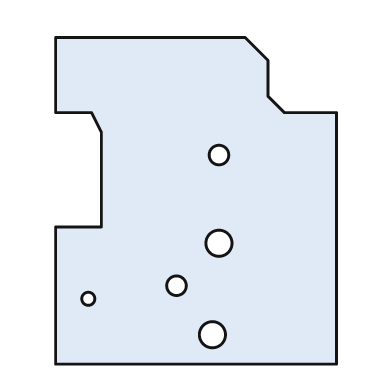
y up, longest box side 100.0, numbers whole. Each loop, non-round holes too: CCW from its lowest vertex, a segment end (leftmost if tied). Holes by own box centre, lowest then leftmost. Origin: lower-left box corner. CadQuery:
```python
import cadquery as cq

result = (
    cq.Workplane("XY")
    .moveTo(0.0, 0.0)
    .lineTo(86.0, 0.0)
    .lineTo(86.0, 77.0)
    .lineTo(70.0, 77.0)
    .lineTo(65.0, 82.0)
    .lineTo(65.0, 93.0)
    .lineTo(58.0, 100.0)
    .lineTo(0.0, 100.0)
    .lineTo(0.0, 77.0)
    .lineTo(11.0, 77.0)
    .lineTo(14.0, 71.0)
    .lineTo(14.0, 42.0)
    .lineTo(0.0, 42.0)
    .close()
    .moveTo(48.0, 9.0)
    .circle(4.0)
    .moveTo(10.0, 20.0)
    .circle(2.0)
    .moveTo(37.0, 24.0)
    .circle(3.0)
    .moveTo(50.0, 37.0)
    .circle(4.0)
    .moveTo(50.0, 64.0)
    .circle(3.0)
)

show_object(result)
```